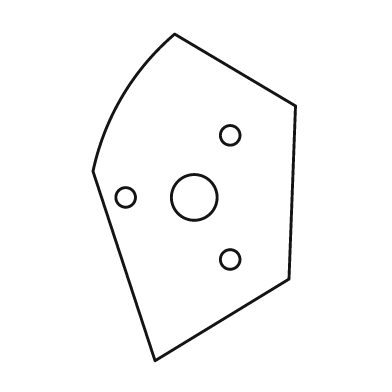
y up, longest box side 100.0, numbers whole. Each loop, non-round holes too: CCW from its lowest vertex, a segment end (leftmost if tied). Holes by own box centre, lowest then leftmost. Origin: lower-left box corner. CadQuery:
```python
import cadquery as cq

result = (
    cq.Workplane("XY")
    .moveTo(19.0, 0.0)
    .lineTo(60.0, 25.0)
    .lineTo(62.0, 78.0)
    .lineTo(25.0, 100.0)
    .threePointArc((9.0, 81.0), (0.0, 58.0))
    .close()
    .moveTo(42.0, 31.0)
    .circle(3.0)
    .moveTo(10.0, 50.0)
    .circle(3.0)
    .moveTo(31.0, 50.0)
    .circle(7.0)
    .moveTo(42.0, 69.0)
    .circle(3.0)
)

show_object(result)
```